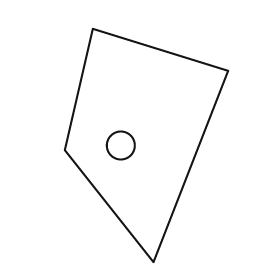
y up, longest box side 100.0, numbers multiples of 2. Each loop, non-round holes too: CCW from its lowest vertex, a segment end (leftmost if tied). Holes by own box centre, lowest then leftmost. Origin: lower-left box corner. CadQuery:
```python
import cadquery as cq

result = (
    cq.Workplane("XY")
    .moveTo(38.0, 0.0)
    .lineTo(70.0, 82.0)
    .lineTo(12.0, 100.0)
    .lineTo(0.0, 48.0)
    .close()
    .moveTo(24.0, 50.0)
    .circle(6.0)
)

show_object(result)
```